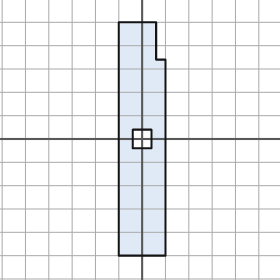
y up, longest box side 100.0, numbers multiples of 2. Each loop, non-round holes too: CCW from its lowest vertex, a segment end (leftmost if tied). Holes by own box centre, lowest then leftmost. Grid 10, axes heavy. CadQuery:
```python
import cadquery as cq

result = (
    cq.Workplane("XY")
    .moveTo(-10.0, -50.0)
    .lineTo(10.0, -50.0)
    .lineTo(10.0, 34.0)
    .lineTo(6.0, 34.0)
    .lineTo(6.0, 50.0)
    .lineTo(-10.0, 50.0)
    .close()
    .moveTo(-4.0, -4.0)
    .lineTo(4.0, -4.0)
    .lineTo(4.0, 4.0)
    .lineTo(-4.0, 4.0)
    .close()
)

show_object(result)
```